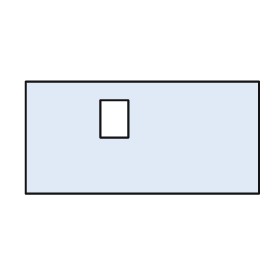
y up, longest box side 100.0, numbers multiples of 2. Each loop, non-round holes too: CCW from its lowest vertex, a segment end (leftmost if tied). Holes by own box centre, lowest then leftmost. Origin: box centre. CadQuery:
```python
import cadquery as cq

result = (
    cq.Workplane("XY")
    .moveTo(-50.0, -24.0)
    .lineTo(50.0, -24.0)
    .lineTo(50.0, 24.0)
    .lineTo(-50.0, 24.0)
    .close()
    .moveTo(-18.0, 0.0)
    .lineTo(-6.0, 0.0)
    .lineTo(-6.0, 16.0)
    .lineTo(-18.0, 16.0)
    .close()
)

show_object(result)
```